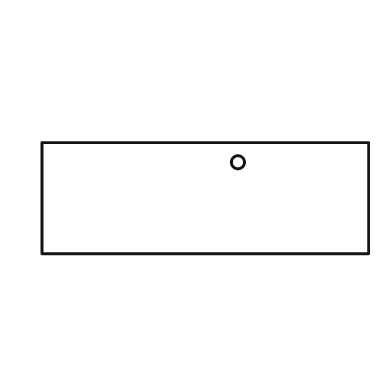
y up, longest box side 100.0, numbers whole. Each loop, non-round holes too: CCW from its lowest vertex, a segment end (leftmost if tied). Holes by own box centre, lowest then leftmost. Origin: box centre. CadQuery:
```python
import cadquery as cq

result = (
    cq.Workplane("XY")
    .moveTo(-50.0, -17.0)
    .lineTo(50.0, -17.0)
    .lineTo(50.0, 17.0)
    .lineTo(-50.0, 17.0)
    .close()
    .moveTo(10.0, 11.0)
    .circle(2.0)
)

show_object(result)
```